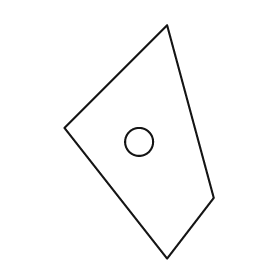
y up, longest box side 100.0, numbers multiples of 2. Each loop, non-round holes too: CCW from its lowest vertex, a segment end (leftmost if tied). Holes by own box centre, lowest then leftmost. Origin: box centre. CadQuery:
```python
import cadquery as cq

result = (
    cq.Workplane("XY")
    .moveTo(12.0, -50.0)
    .lineTo(32.0, -24.0)
    .lineTo(12.0, 50.0)
    .lineTo(-32.0, 6.0)
    .close()
    .moveTo(0.0, 0.0)
    .circle(6.0)
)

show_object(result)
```